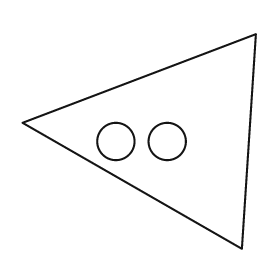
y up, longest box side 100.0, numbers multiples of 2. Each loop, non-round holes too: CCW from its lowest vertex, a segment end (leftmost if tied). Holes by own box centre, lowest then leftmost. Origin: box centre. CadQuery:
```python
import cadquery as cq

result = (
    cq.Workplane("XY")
    .moveTo(44.0, -46.0)
    .lineTo(50.0, 46.0)
    .lineTo(-50.0, 8.0)
    .close()
    .moveTo(-10.0, 0.0)
    .circle(8.0)
    .moveTo(12.0, 0.0)
    .circle(8.0)
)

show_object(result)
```